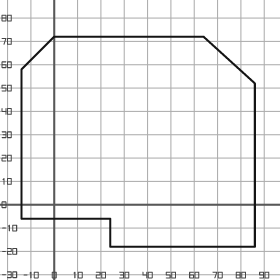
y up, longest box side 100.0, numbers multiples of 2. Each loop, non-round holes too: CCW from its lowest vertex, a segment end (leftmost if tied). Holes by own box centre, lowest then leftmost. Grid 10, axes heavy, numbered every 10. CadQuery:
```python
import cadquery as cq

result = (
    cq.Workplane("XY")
    .moveTo(24.0, -18.0)
    .lineTo(86.0, -18.0)
    .lineTo(86.0, 52.0)
    .lineTo(64.0, 72.0)
    .lineTo(0.0, 72.0)
    .lineTo(-14.0, 58.0)
    .lineTo(-14.0, -6.0)
    .lineTo(24.0, -6.0)
    .close()
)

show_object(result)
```